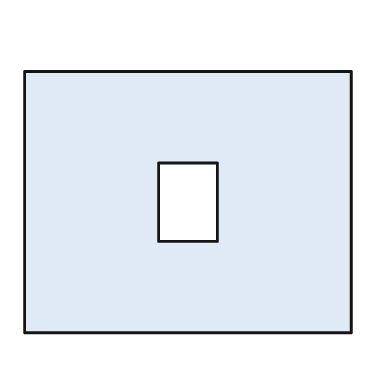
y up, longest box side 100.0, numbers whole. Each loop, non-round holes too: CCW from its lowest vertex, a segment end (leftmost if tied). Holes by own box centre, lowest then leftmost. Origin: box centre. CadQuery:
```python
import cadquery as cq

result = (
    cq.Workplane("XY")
    .moveTo(-50.0, -40.0)
    .lineTo(50.0, -40.0)
    .lineTo(50.0, 40.0)
    .lineTo(-50.0, 40.0)
    .close()
    .moveTo(-9.0, -12.0)
    .lineTo(9.0, -12.0)
    .lineTo(9.0, 12.0)
    .lineTo(-9.0, 12.0)
    .close()
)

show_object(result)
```